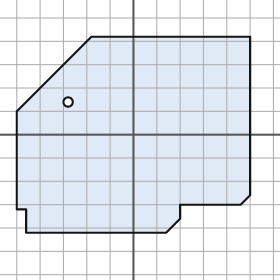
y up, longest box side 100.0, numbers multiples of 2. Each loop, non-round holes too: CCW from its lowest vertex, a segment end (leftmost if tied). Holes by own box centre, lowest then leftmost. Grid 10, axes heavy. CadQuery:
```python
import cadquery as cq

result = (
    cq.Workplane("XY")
    .moveTo(-46.0, -42.0)
    .lineTo(14.0, -42.0)
    .lineTo(20.0, -36.0)
    .lineTo(20.0, -30.0)
    .lineTo(46.0, -30.0)
    .lineTo(50.0, -26.0)
    .lineTo(50.0, 42.0)
    .lineTo(-18.0, 42.0)
    .lineTo(-50.0, 10.0)
    .lineTo(-50.0, -32.0)
    .lineTo(-46.0, -32.0)
    .close()
    .moveTo(-28.0, 14.0)
    .circle(2.0)
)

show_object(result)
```